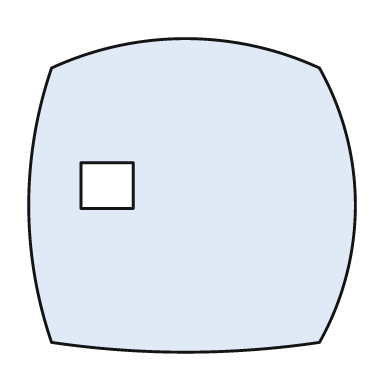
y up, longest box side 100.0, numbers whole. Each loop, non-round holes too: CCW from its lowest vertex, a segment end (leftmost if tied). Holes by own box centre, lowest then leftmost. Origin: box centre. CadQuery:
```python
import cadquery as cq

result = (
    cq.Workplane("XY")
    .moveTo(-43.0, -45.0)
    .threePointArc((-2.0, -48.0), (39.0, -45.0))
    .threePointArc((50.0, -3.0), (39.0, 39.0))
    .threePointArc((-2.0, 48.0), (-43.0, 39.0))
    .threePointArc((-50.0, -3.0), (-43.0, -45.0))
    .close()
    .moveTo(-34.0, -4.0)
    .lineTo(-18.0, -4.0)
    .lineTo(-18.0, 10.0)
    .lineTo(-34.0, 10.0)
    .close()
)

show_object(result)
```